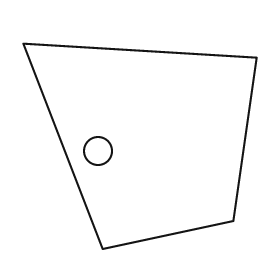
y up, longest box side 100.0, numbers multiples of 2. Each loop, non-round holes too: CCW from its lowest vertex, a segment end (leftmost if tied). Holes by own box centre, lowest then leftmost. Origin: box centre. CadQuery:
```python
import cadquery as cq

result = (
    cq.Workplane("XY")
    .moveTo(-16.0, -44.0)
    .lineTo(40.0, -32.0)
    .lineTo(50.0, 38.0)
    .lineTo(-50.0, 44.0)
    .close()
    .moveTo(-18.0, -2.0)
    .circle(6.0)
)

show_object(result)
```